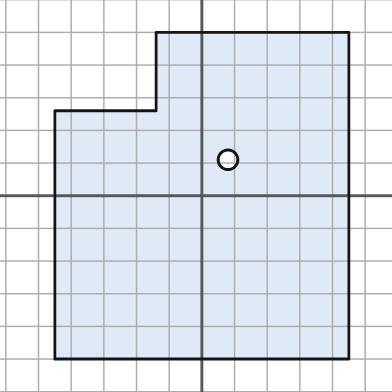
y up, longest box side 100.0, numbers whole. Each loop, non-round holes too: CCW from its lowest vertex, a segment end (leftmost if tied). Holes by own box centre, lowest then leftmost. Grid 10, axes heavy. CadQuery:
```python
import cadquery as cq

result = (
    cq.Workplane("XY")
    .moveTo(-45.0, -50.0)
    .lineTo(45.0, -50.0)
    .lineTo(45.0, 50.0)
    .lineTo(-14.0, 50.0)
    .lineTo(-14.0, 26.0)
    .lineTo(-45.0, 26.0)
    .close()
    .moveTo(8.0, 11.0)
    .circle(3.0)
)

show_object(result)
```